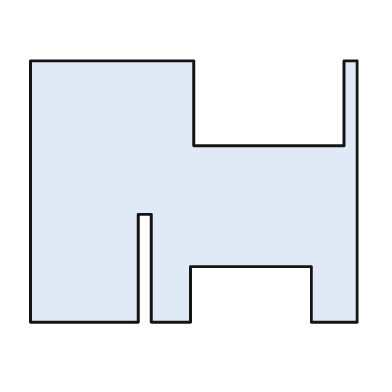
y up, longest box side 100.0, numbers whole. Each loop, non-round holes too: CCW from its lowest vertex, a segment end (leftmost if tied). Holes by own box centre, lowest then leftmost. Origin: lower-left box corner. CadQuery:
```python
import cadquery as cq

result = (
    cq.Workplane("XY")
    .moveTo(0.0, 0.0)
    .lineTo(33.0, 0.0)
    .lineTo(33.0, 33.0)
    .lineTo(37.0, 33.0)
    .lineTo(37.0, 0.0)
    .lineTo(49.0, 0.0)
    .lineTo(49.0, 17.0)
    .lineTo(86.0, 17.0)
    .lineTo(86.0, 0.0)
    .lineTo(100.0, 0.0)
    .lineTo(100.0, 80.0)
    .lineTo(96.0, 80.0)
    .lineTo(96.0, 54.0)
    .lineTo(50.0, 54.0)
    .lineTo(50.0, 80.0)
    .lineTo(0.0, 80.0)
    .close()
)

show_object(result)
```